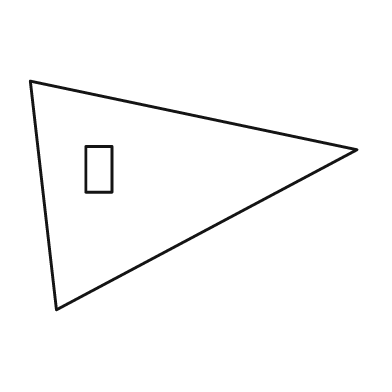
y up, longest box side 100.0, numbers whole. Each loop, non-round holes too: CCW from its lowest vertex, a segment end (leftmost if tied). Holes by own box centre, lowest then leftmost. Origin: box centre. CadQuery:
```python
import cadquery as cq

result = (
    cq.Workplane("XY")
    .moveTo(-42.0, -35.0)
    .lineTo(50.0, 14.0)
    .lineTo(-50.0, 35.0)
    .close()
    .moveTo(-33.0, 1.0)
    .lineTo(-25.0, 1.0)
    .lineTo(-25.0, 15.0)
    .lineTo(-33.0, 15.0)
    .close()
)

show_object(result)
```